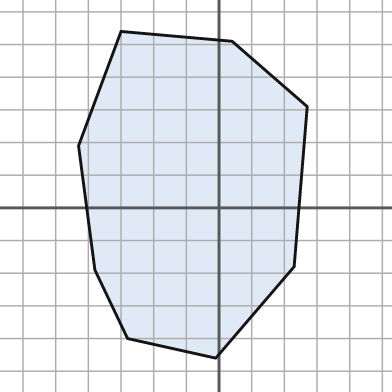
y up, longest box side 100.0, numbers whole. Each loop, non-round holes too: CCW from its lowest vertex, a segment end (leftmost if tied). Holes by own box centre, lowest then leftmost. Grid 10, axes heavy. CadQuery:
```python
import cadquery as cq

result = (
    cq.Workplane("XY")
    .moveTo(-1.0, -46.0)
    .lineTo(23.0, -18.0)
    .lineTo(27.0, 31.0)
    .lineTo(4.0, 51.0)
    .lineTo(-30.0, 54.0)
    .lineTo(-43.0, 19.0)
    .lineTo(-38.0, -19.0)
    .lineTo(-28.0, -40.0)
    .close()
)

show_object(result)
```